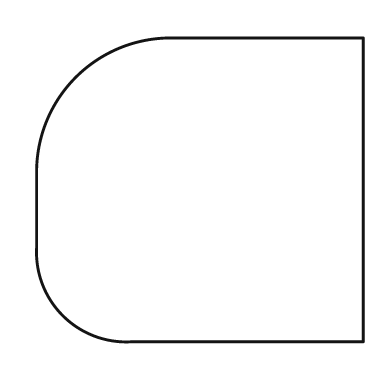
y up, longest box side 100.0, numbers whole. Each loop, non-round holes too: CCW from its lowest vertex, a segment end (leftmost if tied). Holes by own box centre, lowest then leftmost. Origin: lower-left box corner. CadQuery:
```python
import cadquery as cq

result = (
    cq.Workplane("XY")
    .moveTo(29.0, 0.0)
    .lineTo(100.0, 0.0)
    .lineTo(100.0, 93.0)
    .lineTo(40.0, 93.0)
    .threePointArc((12.0, 81.0), (0.0, 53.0))
    .lineTo(0.0, 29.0)
    .threePointArc((8.0, 8.0), (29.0, 0.0))
    .close()
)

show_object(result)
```